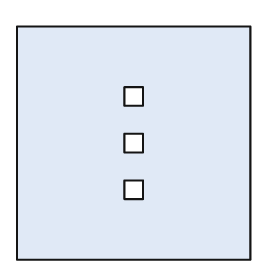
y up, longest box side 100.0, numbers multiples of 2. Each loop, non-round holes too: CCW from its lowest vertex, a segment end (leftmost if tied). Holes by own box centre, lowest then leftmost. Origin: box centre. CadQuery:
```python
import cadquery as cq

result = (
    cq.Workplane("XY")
    .moveTo(-50.0, -50.0)
    .lineTo(50.0, -50.0)
    .lineTo(50.0, 50.0)
    .lineTo(-50.0, 50.0)
    .close()
    .moveTo(-4.0, -24.0)
    .lineTo(4.0, -24.0)
    .lineTo(4.0, -16.0)
    .lineTo(-4.0, -16.0)
    .close()
    .moveTo(-4.0, -4.0)
    .lineTo(4.0, -4.0)
    .lineTo(4.0, 4.0)
    .lineTo(-4.0, 4.0)
    .close()
    .moveTo(-4.0, 16.0)
    .lineTo(4.0, 16.0)
    .lineTo(4.0, 24.0)
    .lineTo(-4.0, 24.0)
    .close()
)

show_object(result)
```